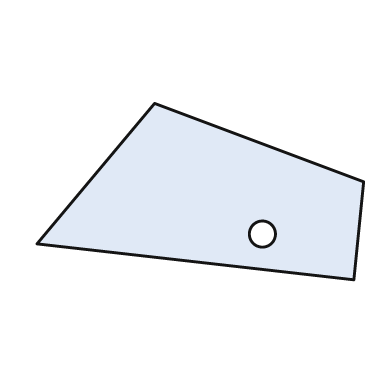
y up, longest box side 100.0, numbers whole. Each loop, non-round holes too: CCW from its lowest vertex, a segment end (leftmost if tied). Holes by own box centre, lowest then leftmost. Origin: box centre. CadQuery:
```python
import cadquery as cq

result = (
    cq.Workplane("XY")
    .moveTo(47.0, -27.0)
    .lineTo(50.0, 3.0)
    .lineTo(-14.0, 27.0)
    .lineTo(-50.0, -16.0)
    .close()
    .moveTo(19.0, -13.0)
    .circle(4.0)
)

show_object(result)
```